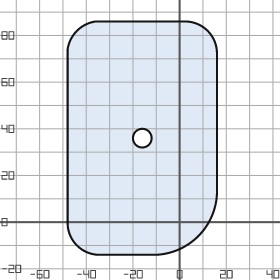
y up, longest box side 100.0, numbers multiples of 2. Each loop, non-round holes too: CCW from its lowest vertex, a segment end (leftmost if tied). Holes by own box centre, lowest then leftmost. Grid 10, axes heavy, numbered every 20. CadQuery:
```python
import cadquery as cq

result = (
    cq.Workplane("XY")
    .moveTo(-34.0, -14.0)
    .lineTo(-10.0, -14.0)
    .threePointArc((8.0, -6.0), (16.0, 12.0))
    .lineTo(16.0, 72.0)
    .threePointArc((12.0, 82.0), (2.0, 86.0))
    .lineTo(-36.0, 86.0)
    .threePointArc((-44.0, 82.0), (-48.0, 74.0))
    .lineTo(-48.0, 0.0)
    .threePointArc((-44.0, -10.0), (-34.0, -14.0))
    .close()
    .moveTo(-16.0, 36.0)
    .circle(4.0)
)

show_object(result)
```